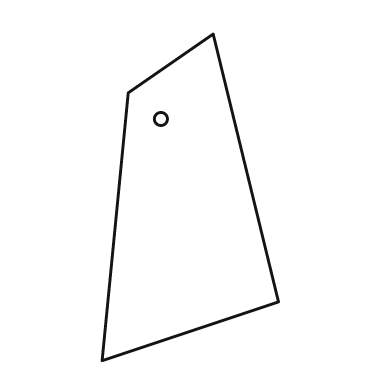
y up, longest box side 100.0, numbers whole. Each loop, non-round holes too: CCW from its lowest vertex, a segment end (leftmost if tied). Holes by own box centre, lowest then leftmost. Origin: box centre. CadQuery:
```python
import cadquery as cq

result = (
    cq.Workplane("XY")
    .moveTo(-27.0, -50.0)
    .lineTo(27.0, -32.0)
    .lineTo(7.0, 50.0)
    .lineTo(-19.0, 32.0)
    .close()
    .moveTo(-9.0, 24.0)
    .circle(2.0)
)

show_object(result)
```